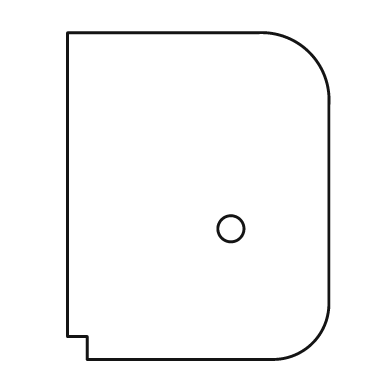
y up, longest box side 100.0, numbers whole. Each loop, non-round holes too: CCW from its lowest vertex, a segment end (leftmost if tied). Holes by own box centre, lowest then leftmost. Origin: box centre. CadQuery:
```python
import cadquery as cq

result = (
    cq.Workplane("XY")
    .moveTo(-34.0, -50.0)
    .lineTo(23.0, -50.0)
    .threePointArc((35.0, -45.0), (40.0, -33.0))
    .lineTo(40.0, 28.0)
    .threePointArc((34.0, 44.0), (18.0, 50.0))
    .lineTo(-40.0, 50.0)
    .lineTo(-40.0, -43.0)
    .lineTo(-34.0, -43.0)
    .close()
    .moveTo(10.0, -10.0)
    .circle(4.0)
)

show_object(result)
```